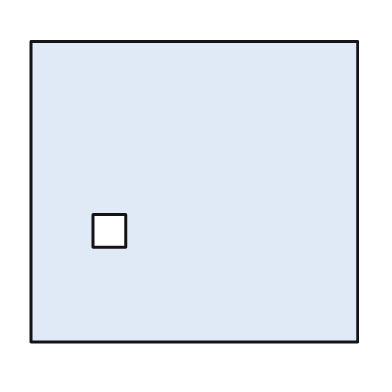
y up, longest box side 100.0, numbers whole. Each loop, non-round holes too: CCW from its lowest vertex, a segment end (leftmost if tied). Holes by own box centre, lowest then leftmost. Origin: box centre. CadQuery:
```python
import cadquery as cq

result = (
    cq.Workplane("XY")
    .moveTo(-50.0, -46.0)
    .lineTo(50.0, -46.0)
    .lineTo(50.0, 46.0)
    .lineTo(-50.0, 46.0)
    .close()
    .moveTo(-31.0, -17.0)
    .lineTo(-21.0, -17.0)
    .lineTo(-21.0, -7.0)
    .lineTo(-31.0, -7.0)
    .close()
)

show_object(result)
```